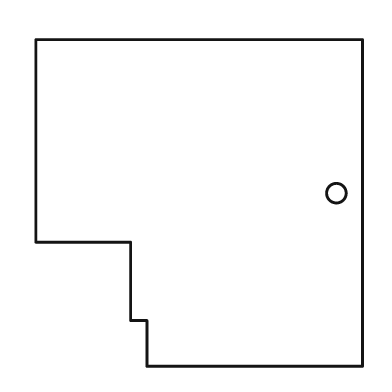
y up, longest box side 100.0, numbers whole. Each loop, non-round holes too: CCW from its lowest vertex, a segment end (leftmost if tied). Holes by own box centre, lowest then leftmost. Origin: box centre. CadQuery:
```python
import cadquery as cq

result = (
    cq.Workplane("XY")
    .moveTo(-16.0, -50.0)
    .lineTo(50.0, -50.0)
    .lineTo(50.0, 50.0)
    .lineTo(-50.0, 50.0)
    .lineTo(-50.0, -12.0)
    .lineTo(-21.0, -12.0)
    .lineTo(-21.0, -36.0)
    .lineTo(-16.0, -36.0)
    .close()
    .moveTo(42.0, 3.0)
    .circle(3.0)
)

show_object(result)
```